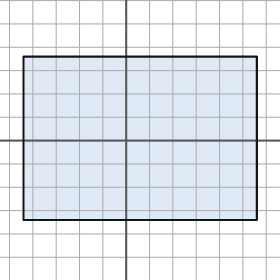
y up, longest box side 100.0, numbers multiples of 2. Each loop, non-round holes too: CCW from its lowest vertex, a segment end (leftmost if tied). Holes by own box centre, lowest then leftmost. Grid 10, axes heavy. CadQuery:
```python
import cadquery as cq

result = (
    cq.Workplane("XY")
    .moveTo(-44.0, -34.0)
    .lineTo(56.0, -34.0)
    .lineTo(56.0, 36.0)
    .lineTo(-44.0, 36.0)
    .close()
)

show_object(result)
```